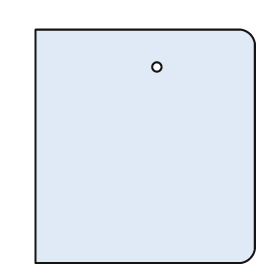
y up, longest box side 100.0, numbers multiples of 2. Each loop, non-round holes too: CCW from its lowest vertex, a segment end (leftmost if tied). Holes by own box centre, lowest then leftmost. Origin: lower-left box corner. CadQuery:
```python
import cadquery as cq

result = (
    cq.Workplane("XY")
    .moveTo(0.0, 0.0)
    .lineTo(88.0, 0.0)
    .threePointArc((92.0, 2.0), (94.0, 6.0))
    .lineTo(94.0, 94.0)
    .threePointArc((92.0, 98.0), (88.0, 100.0))
    .lineTo(0.0, 100.0)
    .close()
    .moveTo(52.0, 84.0)
    .circle(2.0)
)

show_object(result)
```